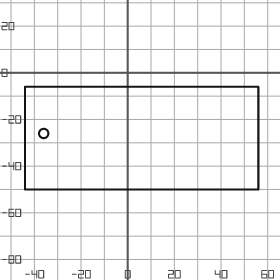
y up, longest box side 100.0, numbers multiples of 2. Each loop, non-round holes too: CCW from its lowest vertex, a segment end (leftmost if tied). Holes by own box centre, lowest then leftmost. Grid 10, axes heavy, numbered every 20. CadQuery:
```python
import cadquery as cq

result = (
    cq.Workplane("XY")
    .moveTo(-44.0, -50.0)
    .lineTo(56.0, -50.0)
    .lineTo(56.0, -6.0)
    .lineTo(-44.0, -6.0)
    .close()
    .moveTo(-36.0, -26.0)
    .circle(2.0)
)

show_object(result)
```